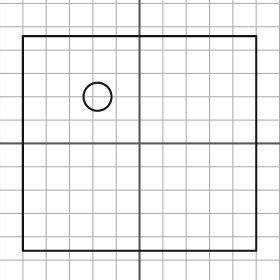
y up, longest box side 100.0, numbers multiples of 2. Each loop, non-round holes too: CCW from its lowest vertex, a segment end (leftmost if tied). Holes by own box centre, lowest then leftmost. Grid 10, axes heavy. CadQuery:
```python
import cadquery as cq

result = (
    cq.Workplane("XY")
    .moveTo(-50.0, -46.0)
    .lineTo(50.0, -46.0)
    .lineTo(50.0, 46.0)
    .lineTo(-50.0, 46.0)
    .close()
    .moveTo(-18.0, 20.0)
    .circle(6.0)
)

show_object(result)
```